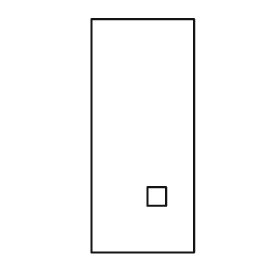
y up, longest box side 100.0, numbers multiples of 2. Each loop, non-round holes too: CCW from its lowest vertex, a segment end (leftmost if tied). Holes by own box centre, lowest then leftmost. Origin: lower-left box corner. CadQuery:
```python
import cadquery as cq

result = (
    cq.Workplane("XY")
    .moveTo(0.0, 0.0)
    .lineTo(44.0, 0.0)
    .lineTo(44.0, 100.0)
    .lineTo(0.0, 100.0)
    .close()
    .moveTo(24.0, 20.0)
    .lineTo(32.0, 20.0)
    .lineTo(32.0, 28.0)
    .lineTo(24.0, 28.0)
    .close()
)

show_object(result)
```